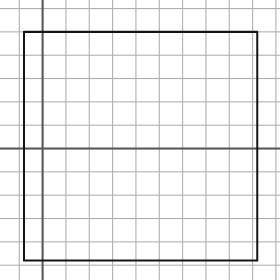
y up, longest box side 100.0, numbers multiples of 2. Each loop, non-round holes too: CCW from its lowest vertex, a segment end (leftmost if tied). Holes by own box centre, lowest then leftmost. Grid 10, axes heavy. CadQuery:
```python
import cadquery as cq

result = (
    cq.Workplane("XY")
    .moveTo(-8.0, -48.0)
    .lineTo(92.0, -48.0)
    .lineTo(92.0, 50.0)
    .lineTo(-8.0, 50.0)
    .close()
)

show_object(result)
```